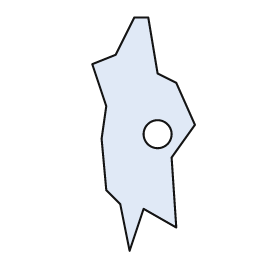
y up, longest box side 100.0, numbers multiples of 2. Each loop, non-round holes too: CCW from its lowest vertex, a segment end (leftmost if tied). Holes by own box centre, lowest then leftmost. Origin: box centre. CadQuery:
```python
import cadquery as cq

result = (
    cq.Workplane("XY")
    .moveTo(-6.0, -50.0)
    .lineTo(0.0, -32.0)
    .lineTo(14.0, -40.0)
    .lineTo(12.0, -10.0)
    .lineTo(22.0, 4.0)
    .lineTo(14.0, 22.0)
    .lineTo(6.0, 26.0)
    .lineTo(2.0, 50.0)
    .lineTo(-4.0, 50.0)
    .lineTo(-12.0, 34.0)
    .lineTo(-22.0, 30.0)
    .lineTo(-16.0, 12.0)
    .lineTo(-18.0, -2.0)
    .lineTo(-16.0, -24.0)
    .lineTo(-10.0, -30.0)
    .close()
    .moveTo(6.0, 0.0)
    .circle(6.0)
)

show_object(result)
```